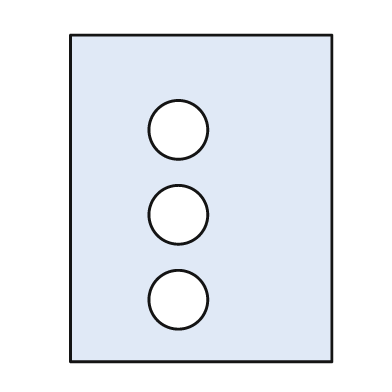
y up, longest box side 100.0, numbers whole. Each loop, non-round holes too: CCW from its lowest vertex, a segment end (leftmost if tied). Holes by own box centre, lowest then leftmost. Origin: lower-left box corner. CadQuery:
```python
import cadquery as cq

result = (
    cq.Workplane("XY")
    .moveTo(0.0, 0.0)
    .lineTo(80.0, 0.0)
    .lineTo(80.0, 100.0)
    .lineTo(0.0, 100.0)
    .close()
    .moveTo(33.0, 19.0)
    .circle(9.0)
    .moveTo(33.0, 45.0)
    .circle(9.0)
    .moveTo(33.0, 71.0)
    .circle(9.0)
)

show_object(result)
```